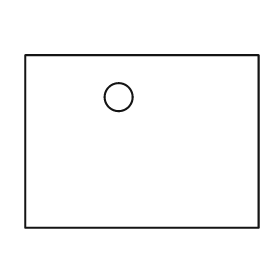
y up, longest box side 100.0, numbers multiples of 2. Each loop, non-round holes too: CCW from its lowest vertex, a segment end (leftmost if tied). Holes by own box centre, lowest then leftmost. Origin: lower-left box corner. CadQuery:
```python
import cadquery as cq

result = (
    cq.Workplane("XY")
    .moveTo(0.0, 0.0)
    .lineTo(100.0, 0.0)
    .lineTo(100.0, 74.0)
    .lineTo(0.0, 74.0)
    .close()
    .moveTo(40.0, 56.0)
    .circle(6.0)
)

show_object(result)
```